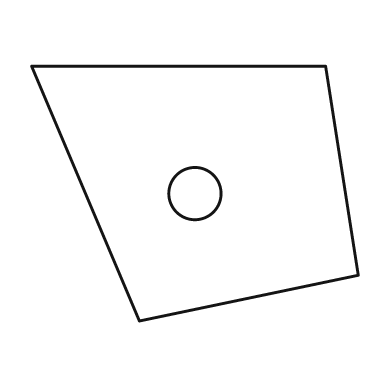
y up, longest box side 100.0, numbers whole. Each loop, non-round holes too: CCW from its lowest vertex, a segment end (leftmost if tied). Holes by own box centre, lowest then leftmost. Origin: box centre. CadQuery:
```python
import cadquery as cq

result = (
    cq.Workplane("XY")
    .moveTo(-17.0, -39.0)
    .lineTo(50.0, -25.0)
    .lineTo(40.0, 39.0)
    .lineTo(-50.0, 39.0)
    .close()
    .moveTo(0.0, 0.0)
    .circle(8.0)
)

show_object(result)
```